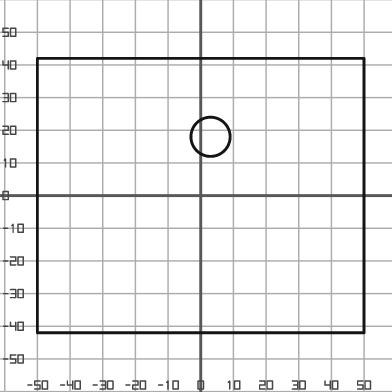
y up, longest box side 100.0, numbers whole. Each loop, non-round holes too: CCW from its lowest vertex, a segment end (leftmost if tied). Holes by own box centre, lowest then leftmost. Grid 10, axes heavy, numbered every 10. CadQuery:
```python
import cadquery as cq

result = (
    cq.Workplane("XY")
    .moveTo(-50.0, -42.0)
    .lineTo(50.0, -42.0)
    .lineTo(50.0, 42.0)
    .lineTo(-50.0, 42.0)
    .close()
    .moveTo(3.0, 18.0)
    .circle(6.0)
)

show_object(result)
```